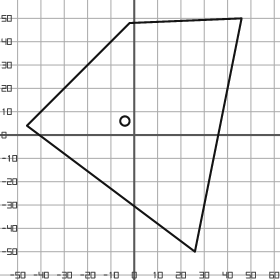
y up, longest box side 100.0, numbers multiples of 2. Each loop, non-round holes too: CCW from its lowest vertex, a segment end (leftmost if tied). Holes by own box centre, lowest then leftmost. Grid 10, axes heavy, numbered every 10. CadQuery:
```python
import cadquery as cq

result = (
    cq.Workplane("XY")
    .moveTo(26.0, -50.0)
    .lineTo(46.0, 50.0)
    .lineTo(-2.0, 48.0)
    .lineTo(-46.0, 4.0)
    .close()
    .moveTo(-4.0, 6.0)
    .circle(2.0)
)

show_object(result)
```